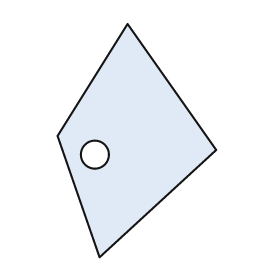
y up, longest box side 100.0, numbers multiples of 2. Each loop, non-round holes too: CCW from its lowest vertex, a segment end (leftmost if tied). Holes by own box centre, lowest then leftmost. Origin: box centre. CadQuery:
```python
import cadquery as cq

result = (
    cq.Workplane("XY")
    .moveTo(-16.0, -50.0)
    .lineTo(34.0, -4.0)
    .lineTo(-4.0, 50.0)
    .lineTo(-34.0, 2.0)
    .close()
    .moveTo(-18.0, -6.0)
    .circle(6.0)
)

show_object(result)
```